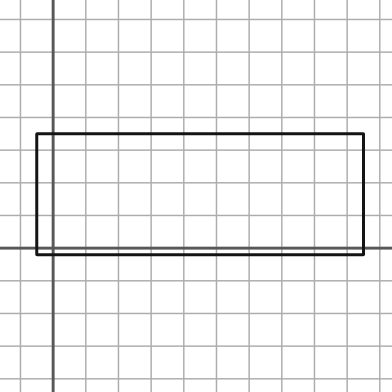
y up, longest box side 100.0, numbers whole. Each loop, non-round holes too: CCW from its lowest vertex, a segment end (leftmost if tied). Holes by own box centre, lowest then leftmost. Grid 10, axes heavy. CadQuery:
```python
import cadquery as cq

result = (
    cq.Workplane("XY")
    .moveTo(-5.0, -2.0)
    .lineTo(95.0, -2.0)
    .lineTo(95.0, 35.0)
    .lineTo(-5.0, 35.0)
    .close()
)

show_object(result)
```